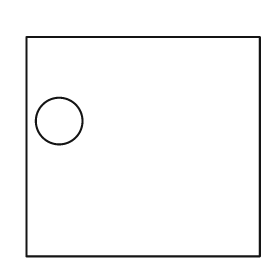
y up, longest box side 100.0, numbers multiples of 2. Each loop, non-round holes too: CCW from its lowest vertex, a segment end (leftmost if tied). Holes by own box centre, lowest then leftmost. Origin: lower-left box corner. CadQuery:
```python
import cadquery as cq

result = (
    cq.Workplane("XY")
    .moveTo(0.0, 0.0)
    .lineTo(100.0, 0.0)
    .lineTo(100.0, 94.0)
    .lineTo(0.0, 94.0)
    .close()
    .moveTo(14.0, 58.0)
    .circle(10.0)
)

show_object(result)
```